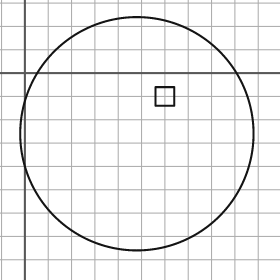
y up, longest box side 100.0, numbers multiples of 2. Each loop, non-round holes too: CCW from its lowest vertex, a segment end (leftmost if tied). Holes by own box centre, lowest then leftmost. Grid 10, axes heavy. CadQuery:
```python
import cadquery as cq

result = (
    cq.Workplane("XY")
    .moveTo(48.0, -26.0)
    .circle(50.0)
    .moveTo(56.0, -14.0)
    .lineTo(64.0, -14.0)
    .lineTo(64.0, -6.0)
    .lineTo(56.0, -6.0)
    .close()
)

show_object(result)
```